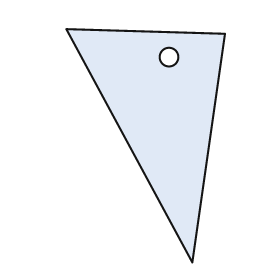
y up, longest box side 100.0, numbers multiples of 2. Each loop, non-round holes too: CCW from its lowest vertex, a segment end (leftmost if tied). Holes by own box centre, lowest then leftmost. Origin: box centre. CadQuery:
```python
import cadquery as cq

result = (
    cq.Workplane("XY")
    .moveTo(20.0, -50.0)
    .lineTo(34.0, 48.0)
    .lineTo(-34.0, 50.0)
    .close()
    .moveTo(10.0, 38.0)
    .circle(4.0)
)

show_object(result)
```